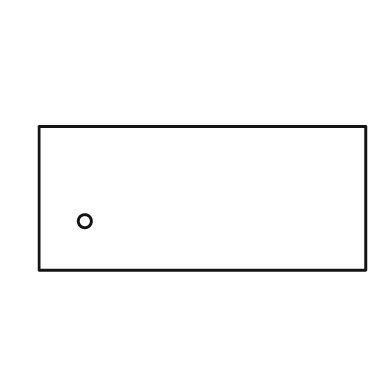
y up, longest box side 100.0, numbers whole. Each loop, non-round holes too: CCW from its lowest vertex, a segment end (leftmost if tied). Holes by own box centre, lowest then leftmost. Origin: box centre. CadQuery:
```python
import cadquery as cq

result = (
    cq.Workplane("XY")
    .moveTo(-50.0, -22.0)
    .lineTo(50.0, -22.0)
    .lineTo(50.0, 22.0)
    .lineTo(-50.0, 22.0)
    .close()
    .moveTo(-36.0, -7.0)
    .circle(2.0)
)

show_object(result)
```